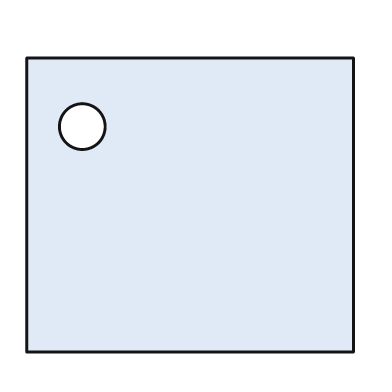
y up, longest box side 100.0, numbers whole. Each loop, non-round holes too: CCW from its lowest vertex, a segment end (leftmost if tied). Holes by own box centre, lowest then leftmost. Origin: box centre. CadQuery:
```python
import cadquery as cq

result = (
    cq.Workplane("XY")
    .moveTo(-50.0, -45.0)
    .lineTo(50.0, -45.0)
    .lineTo(50.0, 45.0)
    .lineTo(-50.0, 45.0)
    .close()
    .moveTo(-33.0, 24.0)
    .circle(7.0)
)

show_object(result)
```